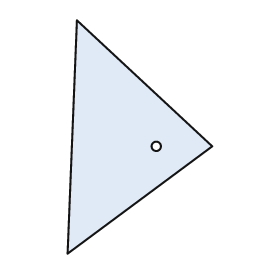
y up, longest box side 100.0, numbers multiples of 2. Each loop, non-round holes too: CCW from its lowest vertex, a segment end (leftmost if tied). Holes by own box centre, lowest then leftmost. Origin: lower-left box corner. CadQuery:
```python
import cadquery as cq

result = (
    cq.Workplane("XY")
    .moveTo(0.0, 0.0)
    .lineTo(62.0, 46.0)
    .lineTo(4.0, 100.0)
    .close()
    .moveTo(38.0, 46.0)
    .circle(2.0)
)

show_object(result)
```